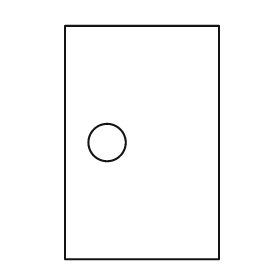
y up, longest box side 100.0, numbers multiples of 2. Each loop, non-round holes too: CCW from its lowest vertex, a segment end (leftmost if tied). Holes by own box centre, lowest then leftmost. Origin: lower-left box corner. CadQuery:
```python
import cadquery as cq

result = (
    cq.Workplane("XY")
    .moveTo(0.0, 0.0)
    .lineTo(66.0, 0.0)
    .lineTo(66.0, 100.0)
    .lineTo(0.0, 100.0)
    .close()
    .moveTo(18.0, 50.0)
    .circle(8.0)
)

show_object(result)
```